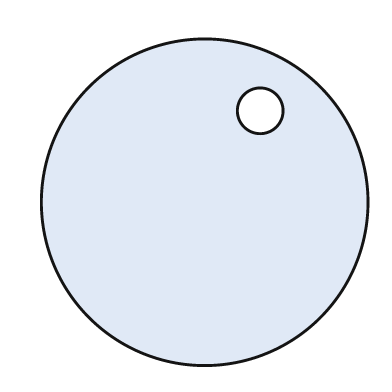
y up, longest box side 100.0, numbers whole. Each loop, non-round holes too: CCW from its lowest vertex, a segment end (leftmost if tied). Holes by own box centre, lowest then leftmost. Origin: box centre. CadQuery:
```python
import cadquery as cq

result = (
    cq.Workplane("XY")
    .moveTo(0.0, 0.0)
    .circle(50.0)
    .moveTo(17.0, 28.0)
    .circle(7.0)
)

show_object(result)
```